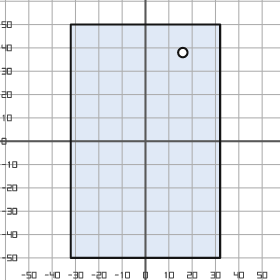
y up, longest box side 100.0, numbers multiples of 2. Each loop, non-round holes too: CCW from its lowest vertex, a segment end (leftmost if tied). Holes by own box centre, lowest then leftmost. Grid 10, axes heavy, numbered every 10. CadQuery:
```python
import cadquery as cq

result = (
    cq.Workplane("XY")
    .moveTo(-32.0, -50.0)
    .lineTo(32.0, -50.0)
    .lineTo(32.0, 50.0)
    .lineTo(-32.0, 50.0)
    .close()
    .moveTo(16.0, 38.0)
    .circle(2.0)
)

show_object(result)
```